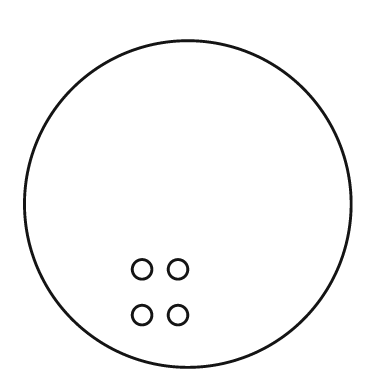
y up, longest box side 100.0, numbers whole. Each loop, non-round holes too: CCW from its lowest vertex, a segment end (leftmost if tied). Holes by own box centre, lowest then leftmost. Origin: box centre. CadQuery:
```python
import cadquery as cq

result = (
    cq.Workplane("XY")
    .moveTo(0.0, 0.0)
    .circle(50.0)
    .moveTo(-14.0, -34.0)
    .circle(3.0)
    .moveTo(-3.0, -34.0)
    .circle(3.0)
    .moveTo(-14.0, -20.0)
    .circle(3.0)
    .moveTo(-3.0, -20.0)
    .circle(3.0)
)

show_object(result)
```